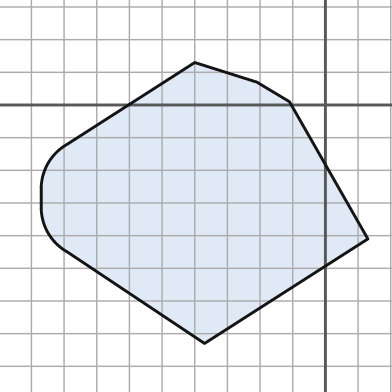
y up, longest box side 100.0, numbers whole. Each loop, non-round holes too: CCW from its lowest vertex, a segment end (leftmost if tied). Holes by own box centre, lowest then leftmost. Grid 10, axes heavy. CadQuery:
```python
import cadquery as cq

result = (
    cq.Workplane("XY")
    .moveTo(-37.0, -73.0)
    .lineTo(13.0, -41.0)
    .lineTo(-11.0, 1.0)
    .lineTo(-21.0, 7.0)
    .lineTo(-40.0, 13.0)
    .lineTo(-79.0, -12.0)
    .threePointArc((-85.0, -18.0), (-87.0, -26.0))
    .lineTo(-87.0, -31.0)
    .threePointArc((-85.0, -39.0), (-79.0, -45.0))
    .close()
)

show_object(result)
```